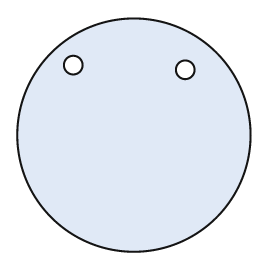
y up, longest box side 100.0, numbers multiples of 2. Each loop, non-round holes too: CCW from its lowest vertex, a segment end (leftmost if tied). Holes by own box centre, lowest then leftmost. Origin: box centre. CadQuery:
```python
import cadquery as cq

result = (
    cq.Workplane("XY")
    .moveTo(0.0, 0.0)
    .circle(50.0)
    .moveTo(22.0, 28.0)
    .circle(4.0)
    .moveTo(-26.0, 30.0)
    .circle(4.0)
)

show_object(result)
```